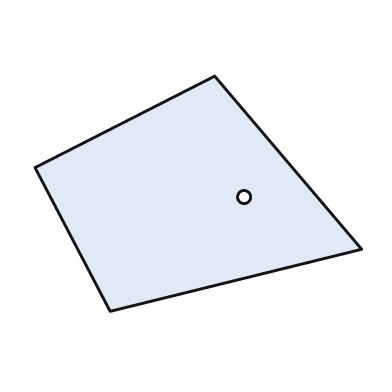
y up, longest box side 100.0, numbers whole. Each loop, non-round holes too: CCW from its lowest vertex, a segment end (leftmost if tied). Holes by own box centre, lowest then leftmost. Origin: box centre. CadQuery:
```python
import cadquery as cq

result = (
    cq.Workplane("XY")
    .moveTo(-27.0, -36.0)
    .lineTo(50.0, -17.0)
    .lineTo(5.0, 36.0)
    .lineTo(-50.0, 8.0)
    .close()
    .moveTo(14.0, -1.0)
    .circle(2.0)
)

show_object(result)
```